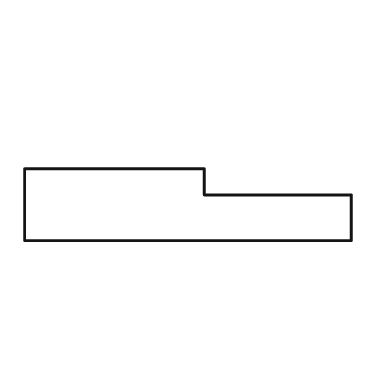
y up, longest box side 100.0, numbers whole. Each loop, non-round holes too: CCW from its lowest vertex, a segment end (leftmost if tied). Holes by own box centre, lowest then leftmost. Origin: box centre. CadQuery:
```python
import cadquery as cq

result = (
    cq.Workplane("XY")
    .moveTo(-50.0, -11.0)
    .lineTo(50.0, -11.0)
    .lineTo(50.0, 3.0)
    .lineTo(5.0, 3.0)
    .lineTo(5.0, 11.0)
    .lineTo(-50.0, 11.0)
    .close()
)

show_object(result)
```